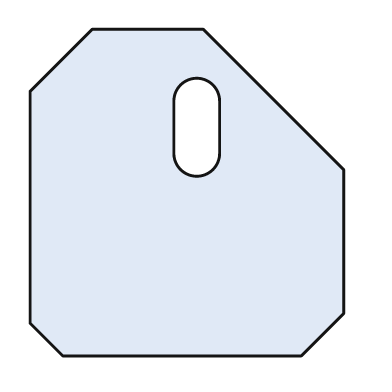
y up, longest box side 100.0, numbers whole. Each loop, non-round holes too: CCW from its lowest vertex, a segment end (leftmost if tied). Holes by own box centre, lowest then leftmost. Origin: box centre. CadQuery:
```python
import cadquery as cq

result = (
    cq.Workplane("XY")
    .moveTo(-38.0, -50.0)
    .lineTo(35.0, -50.0)
    .lineTo(48.0, -37.0)
    .lineTo(48.0, 7.0)
    .lineTo(5.0, 50.0)
    .lineTo(-29.0, 50.0)
    .lineTo(-48.0, 31.0)
    .lineTo(-48.0, -40.0)
    .close()
    .moveTo(-4.0, 12.0)
    .threePointArc((3.0, 5.0), (10.0, 12.0))
    .lineTo(10.0, 28.0)
    .threePointArc((3.0, 35.0), (-4.0, 28.0))
    .close()
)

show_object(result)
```